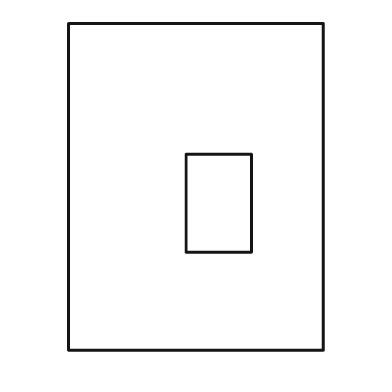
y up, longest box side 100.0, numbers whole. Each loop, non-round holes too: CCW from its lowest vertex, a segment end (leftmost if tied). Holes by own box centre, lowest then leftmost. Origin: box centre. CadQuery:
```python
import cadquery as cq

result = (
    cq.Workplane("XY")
    .moveTo(-39.0, -50.0)
    .lineTo(39.0, -50.0)
    .lineTo(39.0, 50.0)
    .lineTo(-39.0, 50.0)
    .close()
    .moveTo(-3.0, -20.0)
    .lineTo(17.0, -20.0)
    .lineTo(17.0, 10.0)
    .lineTo(-3.0, 10.0)
    .close()
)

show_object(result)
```